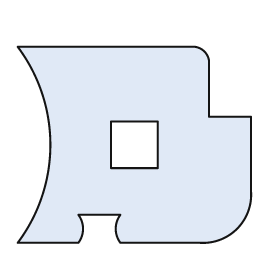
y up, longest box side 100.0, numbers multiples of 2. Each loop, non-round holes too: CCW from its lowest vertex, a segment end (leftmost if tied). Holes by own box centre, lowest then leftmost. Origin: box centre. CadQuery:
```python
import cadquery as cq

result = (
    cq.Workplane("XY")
    .moveTo(-50.0, -42.0)
    .lineTo(-24.0, -42.0)
    .threePointArc((-22.0, -36.0), (-24.0, -30.0))
    .lineTo(-6.0, -30.0)
    .threePointArc((-8.0, -36.0), (-6.0, -42.0))
    .lineTo(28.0, -42.0)
    .threePointArc((44.0, -36.0), (50.0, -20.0))
    .lineTo(50.0, 12.0)
    .lineTo(32.0, 12.0)
    .lineTo(32.0, 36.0)
    .threePointArc((30.0, 40.0), (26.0, 42.0))
    .lineTo(-50.0, 42.0)
    .threePointArc((-36.0, 0.0), (-50.0, -42.0))
    .close()
    .moveTo(-10.0, -10.0)
    .lineTo(10.0, -10.0)
    .lineTo(10.0, 10.0)
    .lineTo(-10.0, 10.0)
    .close()
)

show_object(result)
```